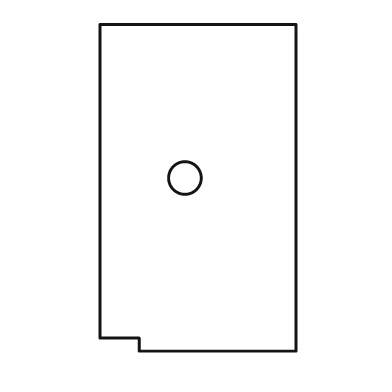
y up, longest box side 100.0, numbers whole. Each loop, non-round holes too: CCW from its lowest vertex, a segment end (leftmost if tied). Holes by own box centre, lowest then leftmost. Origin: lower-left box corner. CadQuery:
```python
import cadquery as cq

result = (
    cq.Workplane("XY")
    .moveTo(12.0, 0.0)
    .lineTo(60.0, 0.0)
    .lineTo(60.0, 100.0)
    .lineTo(0.0, 100.0)
    .lineTo(0.0, 4.0)
    .lineTo(12.0, 4.0)
    .close()
    .moveTo(26.0, 53.0)
    .circle(5.0)
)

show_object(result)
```